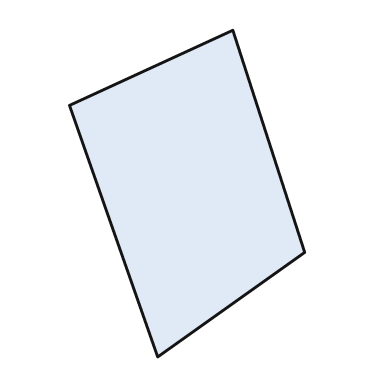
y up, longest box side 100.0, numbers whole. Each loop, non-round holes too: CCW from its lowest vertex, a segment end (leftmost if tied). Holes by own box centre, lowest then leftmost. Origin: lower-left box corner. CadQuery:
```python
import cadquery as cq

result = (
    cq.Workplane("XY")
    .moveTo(27.0, 0.0)
    .lineTo(72.0, 32.0)
    .lineTo(50.0, 100.0)
    .lineTo(0.0, 77.0)
    .close()
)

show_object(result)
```